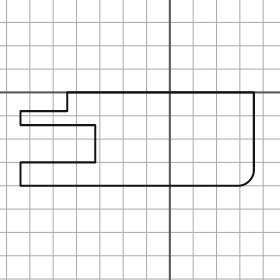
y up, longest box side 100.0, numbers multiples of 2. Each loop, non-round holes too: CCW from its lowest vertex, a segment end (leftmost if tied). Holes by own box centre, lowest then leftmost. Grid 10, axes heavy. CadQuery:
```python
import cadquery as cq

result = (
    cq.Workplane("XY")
    .moveTo(-64.0, -40.0)
    .lineTo(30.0, -40.0)
    .threePointArc((34.0, -38.0), (36.0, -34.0))
    .lineTo(36.0, 0.0)
    .lineTo(-44.0, 0.0)
    .lineTo(-44.0, -8.0)
    .lineTo(-64.0, -8.0)
    .lineTo(-64.0, -14.0)
    .lineTo(-32.0, -14.0)
    .lineTo(-32.0, -30.0)
    .lineTo(-64.0, -30.0)
    .close()
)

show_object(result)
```